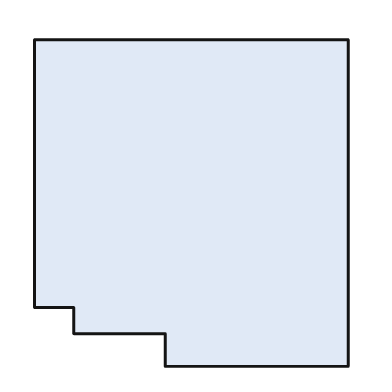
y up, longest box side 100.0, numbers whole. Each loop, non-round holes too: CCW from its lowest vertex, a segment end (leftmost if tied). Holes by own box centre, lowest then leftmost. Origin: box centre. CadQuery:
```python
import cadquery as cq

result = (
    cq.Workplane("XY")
    .moveTo(-8.0, -50.0)
    .lineTo(48.0, -50.0)
    .lineTo(48.0, 50.0)
    .lineTo(-48.0, 50.0)
    .lineTo(-48.0, -32.0)
    .lineTo(-36.0, -32.0)
    .lineTo(-36.0, -40.0)
    .lineTo(-8.0, -40.0)
    .close()
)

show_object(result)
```